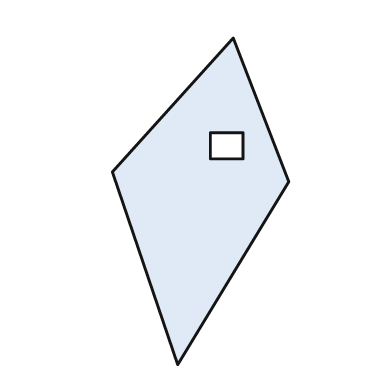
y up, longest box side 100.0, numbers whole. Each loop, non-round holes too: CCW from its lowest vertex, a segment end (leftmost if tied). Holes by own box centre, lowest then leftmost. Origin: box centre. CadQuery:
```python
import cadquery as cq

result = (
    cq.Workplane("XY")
    .moveTo(-7.0, -50.0)
    .lineTo(27.0, 6.0)
    .lineTo(10.0, 50.0)
    .lineTo(-27.0, 9.0)
    .close()
    .moveTo(3.0, 13.0)
    .lineTo(13.0, 13.0)
    .lineTo(13.0, 21.0)
    .lineTo(3.0, 21.0)
    .close()
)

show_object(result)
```